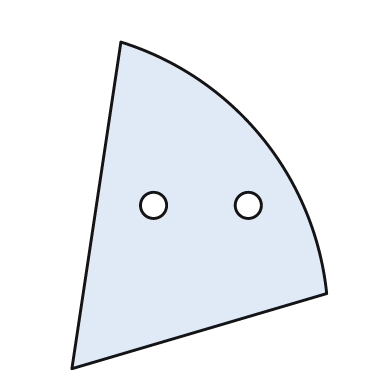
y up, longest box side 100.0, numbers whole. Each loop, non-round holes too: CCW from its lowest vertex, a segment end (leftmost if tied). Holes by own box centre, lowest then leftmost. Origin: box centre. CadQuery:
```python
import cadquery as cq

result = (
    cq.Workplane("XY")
    .moveTo(-39.0, -50.0)
    .lineTo(39.0, -27.0)
    .threePointArc((19.0, 21.0), (-24.0, 50.0))
    .close()
    .moveTo(-14.0, 0.0)
    .circle(4.0)
    .moveTo(15.0, 0.0)
    .circle(4.0)
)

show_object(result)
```